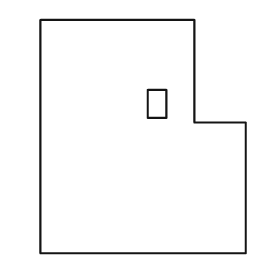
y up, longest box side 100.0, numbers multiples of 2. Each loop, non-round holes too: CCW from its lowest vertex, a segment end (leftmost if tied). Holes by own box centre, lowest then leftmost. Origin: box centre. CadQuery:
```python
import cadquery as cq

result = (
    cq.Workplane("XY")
    .moveTo(-44.0, -50.0)
    .lineTo(44.0, -50.0)
    .lineTo(44.0, 6.0)
    .lineTo(22.0, 6.0)
    .lineTo(22.0, 50.0)
    .lineTo(-44.0, 50.0)
    .close()
    .moveTo(2.0, 8.0)
    .lineTo(10.0, 8.0)
    .lineTo(10.0, 20.0)
    .lineTo(2.0, 20.0)
    .close()
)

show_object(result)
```